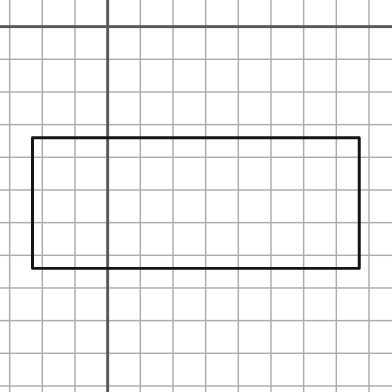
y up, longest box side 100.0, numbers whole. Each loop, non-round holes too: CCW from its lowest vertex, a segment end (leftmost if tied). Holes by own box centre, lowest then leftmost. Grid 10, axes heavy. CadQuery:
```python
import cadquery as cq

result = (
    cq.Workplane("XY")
    .moveTo(-23.0, -74.0)
    .lineTo(77.0, -74.0)
    .lineTo(77.0, -34.0)
    .lineTo(-23.0, -34.0)
    .close()
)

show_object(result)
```